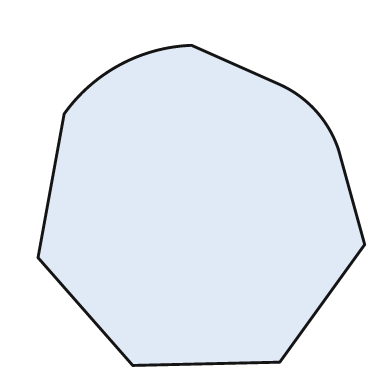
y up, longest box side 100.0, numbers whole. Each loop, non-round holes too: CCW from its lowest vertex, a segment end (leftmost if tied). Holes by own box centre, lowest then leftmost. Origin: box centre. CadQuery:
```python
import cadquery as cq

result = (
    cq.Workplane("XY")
    .moveTo(-21.0, -49.0)
    .lineTo(24.0, -48.0)
    .lineTo(50.0, -12.0)
    .lineTo(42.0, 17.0)
    .threePointArc((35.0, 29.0), (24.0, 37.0))
    .lineTo(-3.0, 49.0)
    .threePointArc((-25.0, 43.0), (-42.0, 28.0))
    .lineTo(-50.0, -16.0)
    .close()
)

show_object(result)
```